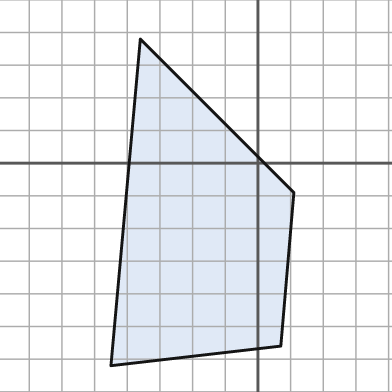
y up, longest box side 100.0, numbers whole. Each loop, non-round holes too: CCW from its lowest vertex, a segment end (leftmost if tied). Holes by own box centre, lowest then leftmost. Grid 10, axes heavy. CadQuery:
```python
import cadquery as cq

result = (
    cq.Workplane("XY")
    .moveTo(-45.0, -62.0)
    .lineTo(7.0, -56.0)
    .lineTo(11.0, -9.0)
    .lineTo(-36.0, 38.0)
    .close()
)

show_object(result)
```